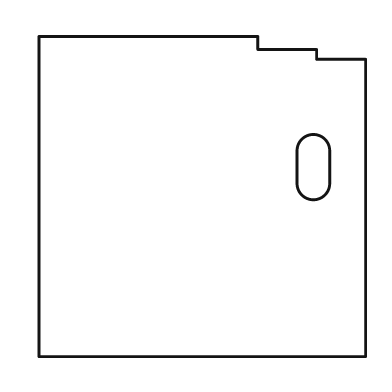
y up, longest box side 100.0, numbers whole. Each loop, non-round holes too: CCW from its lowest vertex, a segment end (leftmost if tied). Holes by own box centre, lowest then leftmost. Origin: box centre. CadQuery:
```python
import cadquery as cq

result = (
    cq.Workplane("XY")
    .moveTo(-50.0, -49.0)
    .lineTo(50.0, -49.0)
    .lineTo(50.0, 42.0)
    .lineTo(35.0, 42.0)
    .lineTo(35.0, 45.0)
    .lineTo(17.0, 45.0)
    .lineTo(17.0, 49.0)
    .lineTo(-50.0, 49.0)
    .close()
    .moveTo(29.0, 4.0)
    .threePointArc((34.0, -1.0), (39.0, 4.0))
    .lineTo(39.0, 14.0)
    .threePointArc((34.0, 19.0), (29.0, 14.0))
    .close()
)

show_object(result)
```